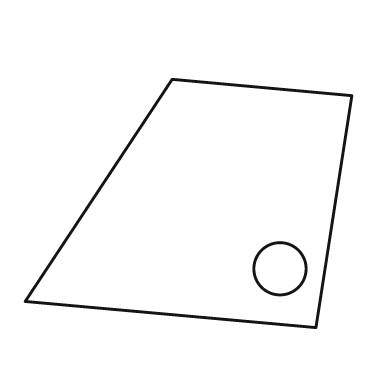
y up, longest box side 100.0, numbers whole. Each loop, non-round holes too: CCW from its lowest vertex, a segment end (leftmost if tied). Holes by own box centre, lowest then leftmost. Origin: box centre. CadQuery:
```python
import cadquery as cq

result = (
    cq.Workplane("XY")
    .moveTo(39.0, -38.0)
    .lineTo(50.0, 33.0)
    .lineTo(-5.0, 38.0)
    .lineTo(-50.0, -30.0)
    .close()
    .moveTo(28.0, -20.0)
    .circle(8.0)
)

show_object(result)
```